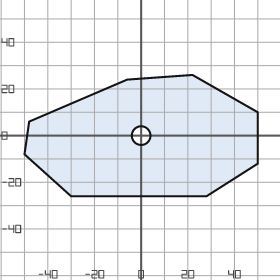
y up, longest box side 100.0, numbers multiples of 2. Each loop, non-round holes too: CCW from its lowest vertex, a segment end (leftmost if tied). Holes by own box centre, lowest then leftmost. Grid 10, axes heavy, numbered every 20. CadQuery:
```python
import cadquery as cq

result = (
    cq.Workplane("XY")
    .moveTo(-30.0, -26.0)
    .lineTo(28.0, -26.0)
    .lineTo(50.0, -12.0)
    .lineTo(50.0, 10.0)
    .lineTo(22.0, 26.0)
    .lineTo(-6.0, 24.0)
    .lineTo(-48.0, 6.0)
    .lineTo(-50.0, -8.0)
    .close()
    .moveTo(0.0, 0.0)
    .circle(4.0)
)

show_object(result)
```